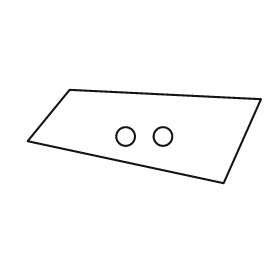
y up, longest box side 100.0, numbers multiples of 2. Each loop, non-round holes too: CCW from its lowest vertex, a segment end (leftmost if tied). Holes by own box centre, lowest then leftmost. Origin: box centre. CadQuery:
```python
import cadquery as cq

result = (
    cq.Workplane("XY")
    .moveTo(34.0, -20.0)
    .lineTo(50.0, 16.0)
    .lineTo(-32.0, 20.0)
    .lineTo(-50.0, -2.0)
    .close()
    .moveTo(-8.0, 0.0)
    .circle(4.0)
    .moveTo(8.0, 0.0)
    .circle(4.0)
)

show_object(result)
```